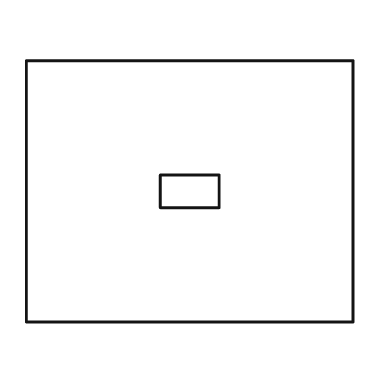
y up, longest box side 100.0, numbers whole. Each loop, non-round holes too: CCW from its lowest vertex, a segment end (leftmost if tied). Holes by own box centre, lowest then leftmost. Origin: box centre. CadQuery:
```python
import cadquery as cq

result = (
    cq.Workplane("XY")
    .moveTo(-50.0, -40.0)
    .lineTo(50.0, -40.0)
    .lineTo(50.0, 40.0)
    .lineTo(-50.0, 40.0)
    .close()
    .moveTo(-9.0, -5.0)
    .lineTo(9.0, -5.0)
    .lineTo(9.0, 5.0)
    .lineTo(-9.0, 5.0)
    .close()
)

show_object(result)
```